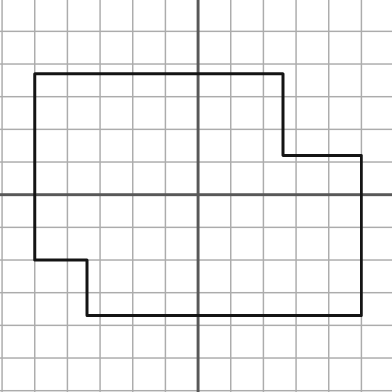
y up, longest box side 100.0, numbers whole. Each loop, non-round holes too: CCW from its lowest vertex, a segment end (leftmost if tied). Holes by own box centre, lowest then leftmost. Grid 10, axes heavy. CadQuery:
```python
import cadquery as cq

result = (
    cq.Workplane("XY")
    .moveTo(-34.0, -37.0)
    .lineTo(50.0, -37.0)
    .lineTo(50.0, 12.0)
    .lineTo(26.0, 12.0)
    .lineTo(26.0, 37.0)
    .lineTo(-50.0, 37.0)
    .lineTo(-50.0, -20.0)
    .lineTo(-34.0, -20.0)
    .close()
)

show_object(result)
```